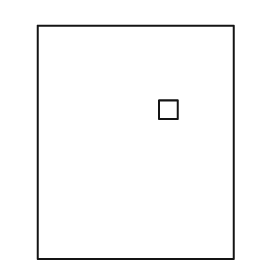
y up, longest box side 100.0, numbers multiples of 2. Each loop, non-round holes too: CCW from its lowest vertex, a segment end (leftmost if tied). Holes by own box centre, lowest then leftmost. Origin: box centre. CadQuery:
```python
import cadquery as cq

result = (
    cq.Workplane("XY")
    .moveTo(-42.0, -50.0)
    .lineTo(42.0, -50.0)
    .lineTo(42.0, 50.0)
    .lineTo(-42.0, 50.0)
    .close()
    .moveTo(10.0, 10.0)
    .lineTo(18.0, 10.0)
    .lineTo(18.0, 18.0)
    .lineTo(10.0, 18.0)
    .close()
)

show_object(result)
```